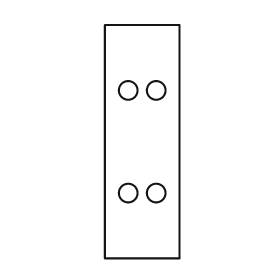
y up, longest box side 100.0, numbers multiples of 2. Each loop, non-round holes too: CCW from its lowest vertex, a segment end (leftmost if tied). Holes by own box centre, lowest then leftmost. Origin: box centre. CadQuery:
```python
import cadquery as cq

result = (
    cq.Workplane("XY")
    .moveTo(-16.0, -50.0)
    .lineTo(16.0, -50.0)
    .lineTo(16.0, 50.0)
    .lineTo(-16.0, 50.0)
    .close()
    .moveTo(-6.0, -22.0)
    .circle(4.0)
    .moveTo(6.0, -22.0)
    .circle(4.0)
    .moveTo(-6.0, 22.0)
    .circle(4.0)
    .moveTo(6.0, 22.0)
    .circle(4.0)
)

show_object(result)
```